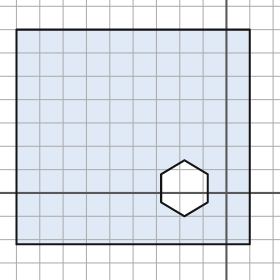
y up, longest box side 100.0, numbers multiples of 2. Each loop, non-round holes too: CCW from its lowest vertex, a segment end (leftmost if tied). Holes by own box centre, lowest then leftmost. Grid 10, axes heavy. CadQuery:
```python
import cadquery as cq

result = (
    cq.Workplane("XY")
    .moveTo(-90.0, -22.0)
    .lineTo(10.0, -22.0)
    .lineTo(10.0, 70.0)
    .lineTo(-90.0, 70.0)
    .close()
    .moveTo(-18.0, -10.0)
    .lineTo(-8.0, -4.0)
    .lineTo(-8.0, 8.0)
    .lineTo(-18.0, 14.0)
    .lineTo(-28.0, 8.0)
    .lineTo(-28.0, -4.0)
    .close()
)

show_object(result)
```